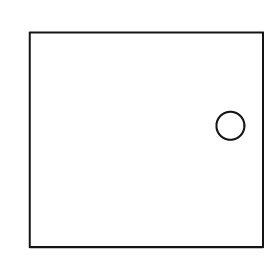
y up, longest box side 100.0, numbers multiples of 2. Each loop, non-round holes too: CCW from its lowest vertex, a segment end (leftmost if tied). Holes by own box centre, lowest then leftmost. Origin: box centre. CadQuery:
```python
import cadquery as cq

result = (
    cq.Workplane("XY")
    .moveTo(-50.0, -46.0)
    .lineTo(50.0, -46.0)
    .lineTo(50.0, 46.0)
    .lineTo(-50.0, 46.0)
    .close()
    .moveTo(36.0, 6.0)
    .circle(6.0)
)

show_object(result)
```